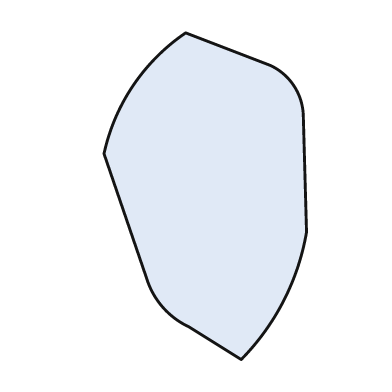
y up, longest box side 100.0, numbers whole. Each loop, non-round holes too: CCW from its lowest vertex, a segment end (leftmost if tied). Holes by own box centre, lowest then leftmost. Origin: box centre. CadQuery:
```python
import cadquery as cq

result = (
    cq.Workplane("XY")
    .moveTo(11.0, -50.0)
    .threePointArc((24.0, -32.0), (31.0, -11.0))
    .lineTo(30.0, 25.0)
    .threePointArc((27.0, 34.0), (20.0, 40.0))
    .lineTo(-6.0, 50.0)
    .threePointArc((-22.0, 34.0), (-31.0, 13.0))
    .lineTo(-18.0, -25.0)
    .threePointArc((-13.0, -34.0), (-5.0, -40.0))
    .close()
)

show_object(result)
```